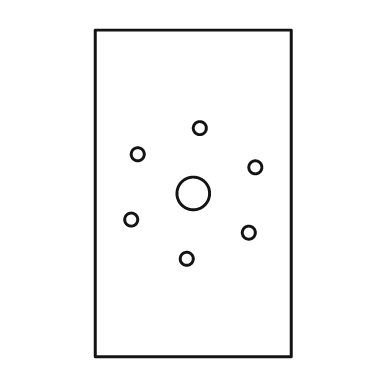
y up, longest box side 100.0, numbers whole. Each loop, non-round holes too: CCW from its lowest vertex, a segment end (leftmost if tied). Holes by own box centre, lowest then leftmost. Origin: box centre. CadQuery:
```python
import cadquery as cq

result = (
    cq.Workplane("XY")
    .moveTo(-30.0, -50.0)
    .lineTo(30.0, -50.0)
    .lineTo(30.0, 50.0)
    .lineTo(-30.0, 50.0)
    .close()
    .moveTo(-2.0, -20.0)
    .circle(2.0)
    .moveTo(17.0, -12.0)
    .circle(2.0)
    .moveTo(-19.0, -8.0)
    .circle(2.0)
    .moveTo(0.0, 0.0)
    .circle(5.0)
    .moveTo(19.0, 8.0)
    .circle(2.0)
    .moveTo(-17.0, 12.0)
    .circle(2.0)
    .moveTo(2.0, 20.0)
    .circle(2.0)
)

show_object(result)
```